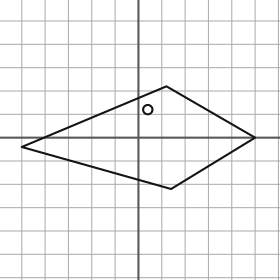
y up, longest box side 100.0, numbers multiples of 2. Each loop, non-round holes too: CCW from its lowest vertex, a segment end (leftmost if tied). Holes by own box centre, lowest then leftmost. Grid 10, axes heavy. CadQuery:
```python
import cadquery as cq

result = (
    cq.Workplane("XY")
    .moveTo(14.0, -22.0)
    .lineTo(50.0, 0.0)
    .lineTo(12.0, 22.0)
    .lineTo(-50.0, -4.0)
    .close()
    .moveTo(4.0, 12.0)
    .circle(2.0)
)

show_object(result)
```